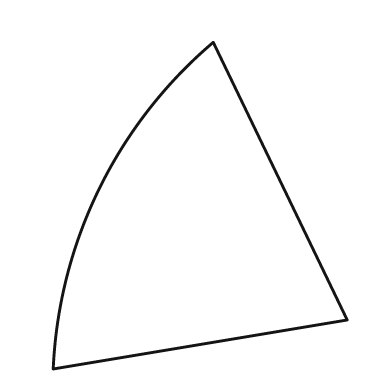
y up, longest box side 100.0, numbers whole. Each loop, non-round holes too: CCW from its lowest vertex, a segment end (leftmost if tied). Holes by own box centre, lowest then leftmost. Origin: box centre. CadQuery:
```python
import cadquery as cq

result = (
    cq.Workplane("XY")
    .moveTo(-45.0, -50.0)
    .lineTo(45.0, -35.0)
    .lineTo(4.0, 50.0)
    .threePointArc((-31.0, 5.0), (-45.0, -50.0))
    .close()
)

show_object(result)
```